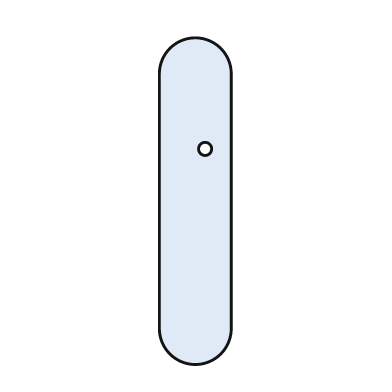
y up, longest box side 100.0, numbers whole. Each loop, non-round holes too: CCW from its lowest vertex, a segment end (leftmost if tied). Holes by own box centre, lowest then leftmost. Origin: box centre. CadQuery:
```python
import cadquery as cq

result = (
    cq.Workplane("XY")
    .moveTo(-11.0, -39.0)
    .threePointArc((0.0, -50.0), (11.0, -39.0))
    .lineTo(11.0, 39.0)
    .threePointArc((0.0, 50.0), (-11.0, 39.0))
    .close()
    .moveTo(3.0, 16.0)
    .circle(2.0)
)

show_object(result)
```